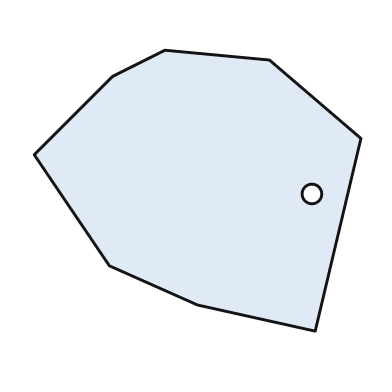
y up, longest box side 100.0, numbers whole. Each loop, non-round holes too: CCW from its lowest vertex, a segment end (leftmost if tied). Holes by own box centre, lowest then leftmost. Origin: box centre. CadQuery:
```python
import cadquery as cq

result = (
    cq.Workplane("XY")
    .moveTo(36.0, -43.0)
    .lineTo(50.0, 16.0)
    .lineTo(22.0, 40.0)
    .lineTo(-10.0, 43.0)
    .lineTo(-26.0, 35.0)
    .lineTo(-50.0, 11.0)
    .lineTo(-27.0, -23.0)
    .lineTo(0.0, -35.0)
    .close()
    .moveTo(35.0, -1.0)
    .circle(3.0)
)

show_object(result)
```